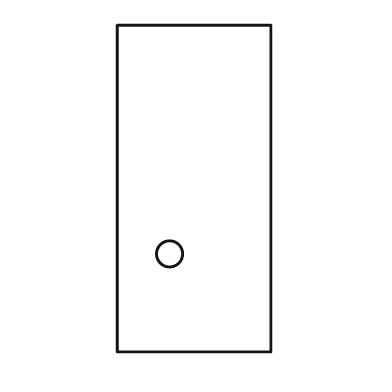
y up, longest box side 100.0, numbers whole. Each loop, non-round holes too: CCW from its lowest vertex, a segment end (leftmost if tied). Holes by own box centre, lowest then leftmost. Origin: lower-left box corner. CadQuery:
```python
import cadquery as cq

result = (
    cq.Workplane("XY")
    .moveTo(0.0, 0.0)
    .lineTo(47.0, 0.0)
    .lineTo(47.0, 100.0)
    .lineTo(0.0, 100.0)
    .close()
    .moveTo(16.0, 30.0)
    .circle(4.0)
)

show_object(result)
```